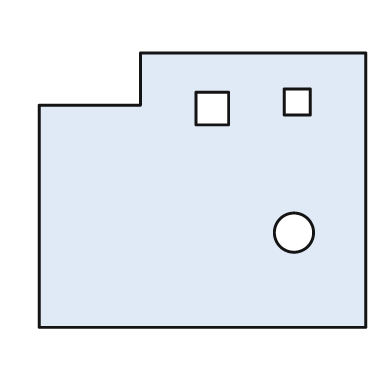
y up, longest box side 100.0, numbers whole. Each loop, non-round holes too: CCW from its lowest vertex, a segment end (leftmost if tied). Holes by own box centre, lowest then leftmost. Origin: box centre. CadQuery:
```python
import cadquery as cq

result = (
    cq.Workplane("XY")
    .moveTo(-50.0, -42.0)
    .lineTo(50.0, -42.0)
    .lineTo(50.0, 42.0)
    .lineTo(-19.0, 42.0)
    .lineTo(-19.0, 26.0)
    .lineTo(-50.0, 26.0)
    .close()
    .moveTo(28.0, -13.0)
    .circle(6.0)
    .moveTo(-2.0, 20.0)
    .lineTo(8.0, 20.0)
    .lineTo(8.0, 30.0)
    .lineTo(-2.0, 30.0)
    .close()
    .moveTo(25.0, 23.0)
    .lineTo(33.0, 23.0)
    .lineTo(33.0, 31.0)
    .lineTo(25.0, 31.0)
    .close()
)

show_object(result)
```